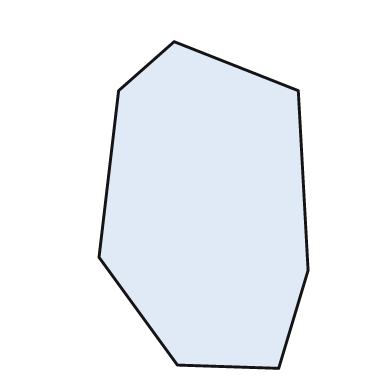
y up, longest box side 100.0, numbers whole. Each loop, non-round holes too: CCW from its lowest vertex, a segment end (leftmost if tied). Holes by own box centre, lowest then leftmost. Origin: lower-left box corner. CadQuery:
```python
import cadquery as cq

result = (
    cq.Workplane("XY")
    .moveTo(55.0, 0.0)
    .lineTo(64.0, 30.0)
    .lineTo(61.0, 85.0)
    .lineTo(23.0, 100.0)
    .lineTo(6.0, 85.0)
    .lineTo(0.0, 34.0)
    .lineTo(24.0, 1.0)
    .close()
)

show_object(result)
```